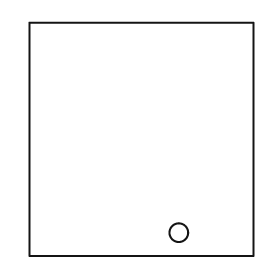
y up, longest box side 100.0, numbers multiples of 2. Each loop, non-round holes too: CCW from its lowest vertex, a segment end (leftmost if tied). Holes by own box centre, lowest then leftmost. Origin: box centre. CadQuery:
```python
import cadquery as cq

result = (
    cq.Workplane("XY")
    .moveTo(-48.0, -50.0)
    .lineTo(48.0, -50.0)
    .lineTo(48.0, 50.0)
    .lineTo(-48.0, 50.0)
    .close()
    .moveTo(16.0, -40.0)
    .circle(4.0)
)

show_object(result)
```